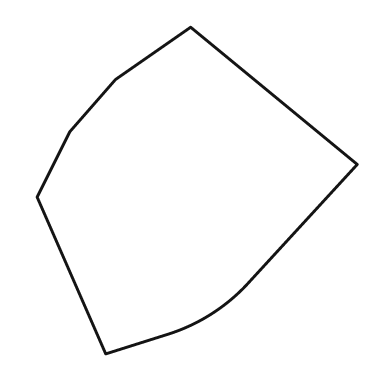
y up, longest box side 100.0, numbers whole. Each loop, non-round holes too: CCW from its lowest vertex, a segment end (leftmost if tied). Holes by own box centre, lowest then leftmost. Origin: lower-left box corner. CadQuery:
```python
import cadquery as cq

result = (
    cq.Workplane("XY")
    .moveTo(21.0, 0.0)
    .lineTo(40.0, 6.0)
    .threePointArc((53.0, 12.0), (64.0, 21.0))
    .lineTo(98.0, 58.0)
    .lineTo(47.0, 100.0)
    .lineTo(24.0, 84.0)
    .lineTo(10.0, 68.0)
    .lineTo(0.0, 48.0)
    .close()
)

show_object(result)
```